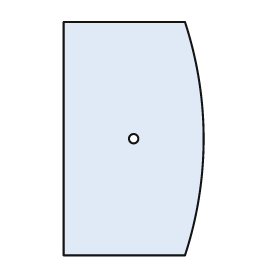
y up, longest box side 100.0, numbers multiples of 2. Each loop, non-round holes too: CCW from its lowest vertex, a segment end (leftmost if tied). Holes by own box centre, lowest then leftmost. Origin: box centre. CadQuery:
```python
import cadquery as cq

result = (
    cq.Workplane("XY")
    .moveTo(-30.0, -50.0)
    .lineTo(22.0, -50.0)
    .threePointArc((30.0, 0.0), (22.0, 50.0))
    .lineTo(-30.0, 50.0)
    .close()
    .moveTo(0.0, 0.0)
    .circle(2.0)
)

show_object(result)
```